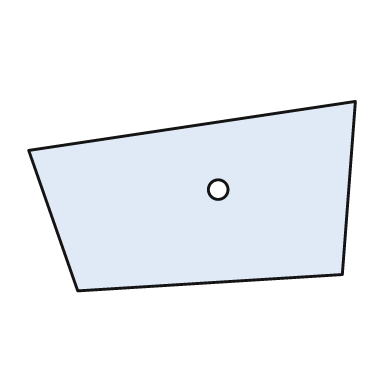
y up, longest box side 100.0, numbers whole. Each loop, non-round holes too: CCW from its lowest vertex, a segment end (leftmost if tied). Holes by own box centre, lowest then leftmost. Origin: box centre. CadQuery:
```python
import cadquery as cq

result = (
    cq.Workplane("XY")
    .moveTo(-35.0, -29.0)
    .lineTo(46.0, -24.0)
    .lineTo(50.0, 29.0)
    .lineTo(-50.0, 14.0)
    .close()
    .moveTo(8.0, 2.0)
    .circle(3.0)
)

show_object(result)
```